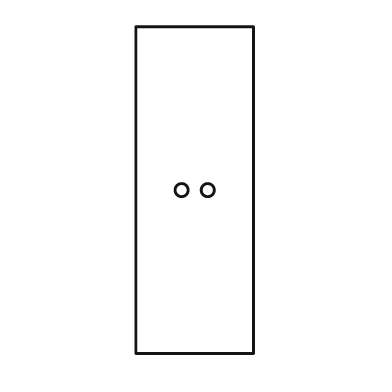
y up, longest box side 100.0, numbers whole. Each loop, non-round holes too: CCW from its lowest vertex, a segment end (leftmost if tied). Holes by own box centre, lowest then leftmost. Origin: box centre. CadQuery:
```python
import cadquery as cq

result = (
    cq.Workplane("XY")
    .moveTo(-18.0, -50.0)
    .lineTo(18.0, -50.0)
    .lineTo(18.0, 50.0)
    .lineTo(-18.0, 50.0)
    .close()
    .moveTo(-4.0, 0.0)
    .circle(2.0)
    .moveTo(4.0, 0.0)
    .circle(2.0)
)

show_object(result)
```